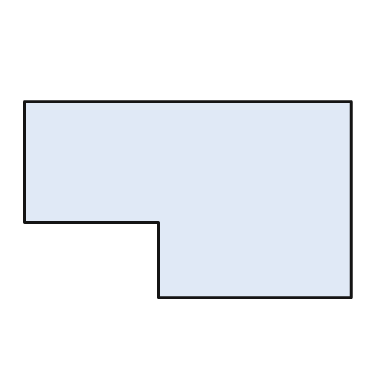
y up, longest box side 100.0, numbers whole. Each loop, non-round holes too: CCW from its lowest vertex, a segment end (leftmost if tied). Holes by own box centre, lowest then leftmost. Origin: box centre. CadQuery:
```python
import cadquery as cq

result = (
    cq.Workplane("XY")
    .moveTo(-9.0, -30.0)
    .lineTo(50.0, -30.0)
    .lineTo(50.0, 30.0)
    .lineTo(-50.0, 30.0)
    .lineTo(-50.0, -7.0)
    .lineTo(-9.0, -7.0)
    .close()
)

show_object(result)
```